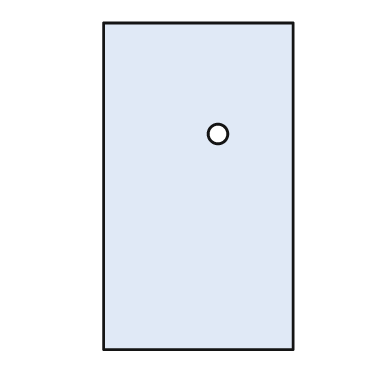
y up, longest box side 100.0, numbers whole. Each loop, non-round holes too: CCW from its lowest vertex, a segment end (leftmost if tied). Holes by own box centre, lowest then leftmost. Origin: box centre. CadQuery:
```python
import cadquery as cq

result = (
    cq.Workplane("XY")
    .moveTo(-29.0, -50.0)
    .lineTo(29.0, -50.0)
    .lineTo(29.0, 50.0)
    .lineTo(-29.0, 50.0)
    .close()
    .moveTo(6.0, 16.0)
    .circle(3.0)
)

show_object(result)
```